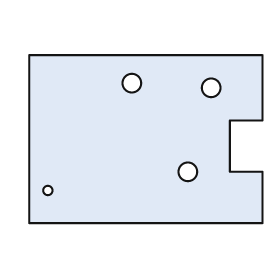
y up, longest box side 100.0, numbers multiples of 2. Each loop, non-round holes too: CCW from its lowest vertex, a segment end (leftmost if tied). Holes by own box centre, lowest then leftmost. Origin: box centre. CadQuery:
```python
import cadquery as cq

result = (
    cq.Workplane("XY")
    .moveTo(-50.0, -36.0)
    .lineTo(50.0, -36.0)
    .lineTo(50.0, -14.0)
    .lineTo(36.0, -14.0)
    .lineTo(36.0, 8.0)
    .lineTo(50.0, 8.0)
    .lineTo(50.0, 36.0)
    .lineTo(-50.0, 36.0)
    .close()
    .moveTo(-42.0, -22.0)
    .circle(2.0)
    .moveTo(18.0, -14.0)
    .circle(4.0)
    .moveTo(28.0, 22.0)
    .circle(4.0)
    .moveTo(-6.0, 24.0)
    .circle(4.0)
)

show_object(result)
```